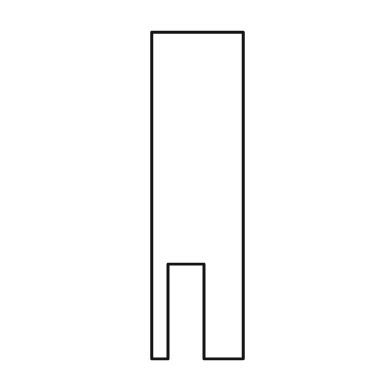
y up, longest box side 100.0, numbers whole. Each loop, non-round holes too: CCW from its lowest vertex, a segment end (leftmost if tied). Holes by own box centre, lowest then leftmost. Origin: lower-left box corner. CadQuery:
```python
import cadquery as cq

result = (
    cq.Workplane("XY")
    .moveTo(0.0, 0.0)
    .lineTo(5.0, 0.0)
    .lineTo(5.0, 29.0)
    .lineTo(16.0, 29.0)
    .lineTo(16.0, 0.0)
    .lineTo(28.0, 0.0)
    .lineTo(28.0, 100.0)
    .lineTo(0.0, 100.0)
    .close()
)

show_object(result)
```